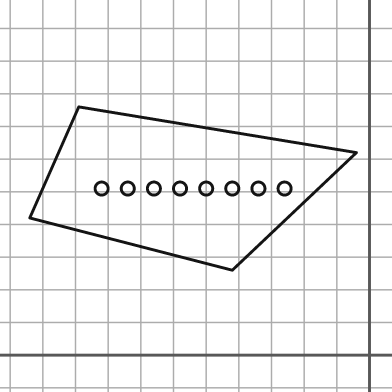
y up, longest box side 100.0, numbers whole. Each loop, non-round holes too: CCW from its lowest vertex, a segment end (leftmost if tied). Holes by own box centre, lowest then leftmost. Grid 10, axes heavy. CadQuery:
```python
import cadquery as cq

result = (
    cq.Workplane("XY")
    .moveTo(-42.0, 26.0)
    .lineTo(-4.0, 62.0)
    .lineTo(-89.0, 76.0)
    .lineTo(-104.0, 42.0)
    .close()
    .moveTo(-82.0, 51.0)
    .circle(2.0)
    .moveTo(-74.0, 51.0)
    .circle(2.0)
    .moveTo(-66.0, 51.0)
    .circle(2.0)
    .moveTo(-58.0, 51.0)
    .circle(2.0)
    .moveTo(-50.0, 51.0)
    .circle(2.0)
    .moveTo(-42.0, 51.0)
    .circle(2.0)
    .moveTo(-34.0, 51.0)
    .circle(2.0)
    .moveTo(-26.0, 51.0)
    .circle(2.0)
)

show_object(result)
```